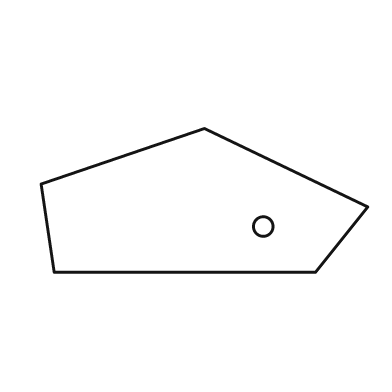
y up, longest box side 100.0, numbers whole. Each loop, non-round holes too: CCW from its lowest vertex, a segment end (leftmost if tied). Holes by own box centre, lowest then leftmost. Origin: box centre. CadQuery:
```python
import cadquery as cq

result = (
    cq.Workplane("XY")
    .moveTo(-46.0, -22.0)
    .lineTo(34.0, -22.0)
    .lineTo(50.0, -2.0)
    .lineTo(0.0, 22.0)
    .lineTo(-50.0, 5.0)
    .close()
    .moveTo(18.0, -8.0)
    .circle(3.0)
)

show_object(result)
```